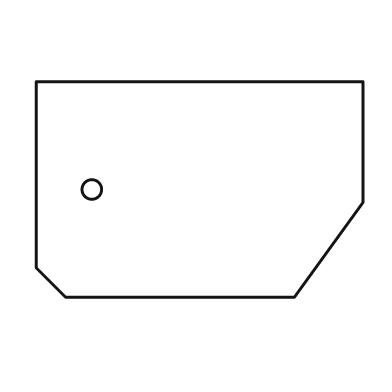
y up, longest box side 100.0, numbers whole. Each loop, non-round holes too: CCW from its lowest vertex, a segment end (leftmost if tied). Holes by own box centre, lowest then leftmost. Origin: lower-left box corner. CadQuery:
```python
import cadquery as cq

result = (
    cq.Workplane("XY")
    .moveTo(9.0, 0.0)
    .lineTo(79.0, 0.0)
    .lineTo(100.0, 29.0)
    .lineTo(100.0, 66.0)
    .lineTo(0.0, 66.0)
    .lineTo(0.0, 9.0)
    .close()
    .moveTo(17.0, 33.0)
    .circle(3.0)
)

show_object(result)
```